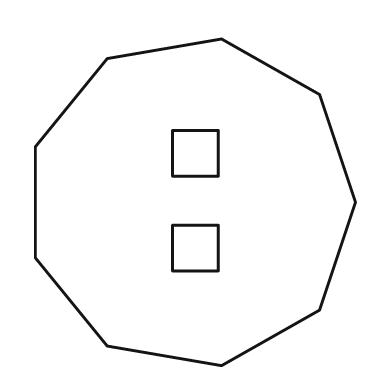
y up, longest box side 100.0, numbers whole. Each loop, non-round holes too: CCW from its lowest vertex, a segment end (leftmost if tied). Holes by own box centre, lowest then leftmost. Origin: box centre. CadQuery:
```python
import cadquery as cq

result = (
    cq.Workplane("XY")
    .moveTo(8.0, -50.0)
    .lineTo(38.0, -33.0)
    .lineTo(49.0, 0.0)
    .lineTo(38.0, 33.0)
    .lineTo(8.0, 50.0)
    .lineTo(-27.0, 44.0)
    .lineTo(-49.0, 17.0)
    .lineTo(-49.0, -17.0)
    .lineTo(-27.0, -44.0)
    .close()
    .moveTo(-7.0, -21.0)
    .lineTo(7.0, -21.0)
    .lineTo(7.0, -7.0)
    .lineTo(-7.0, -7.0)
    .close()
    .moveTo(-7.0, 8.0)
    .lineTo(7.0, 8.0)
    .lineTo(7.0, 22.0)
    .lineTo(-7.0, 22.0)
    .close()
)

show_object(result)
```